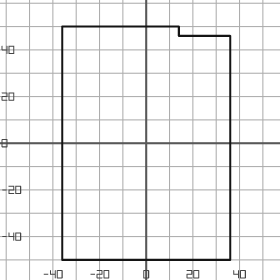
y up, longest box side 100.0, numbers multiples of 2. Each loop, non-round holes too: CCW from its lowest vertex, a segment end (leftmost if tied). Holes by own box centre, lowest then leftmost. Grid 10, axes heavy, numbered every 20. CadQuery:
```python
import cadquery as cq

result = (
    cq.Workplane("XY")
    .moveTo(-36.0, -50.0)
    .lineTo(36.0, -50.0)
    .lineTo(36.0, 46.0)
    .lineTo(14.0, 46.0)
    .lineTo(14.0, 50.0)
    .lineTo(-36.0, 50.0)
    .close()
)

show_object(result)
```